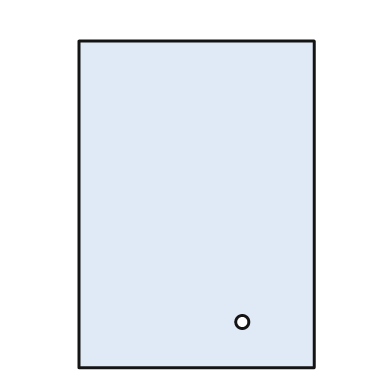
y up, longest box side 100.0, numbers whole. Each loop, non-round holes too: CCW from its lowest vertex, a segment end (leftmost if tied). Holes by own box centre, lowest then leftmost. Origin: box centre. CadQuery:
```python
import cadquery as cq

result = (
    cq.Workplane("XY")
    .moveTo(-36.0, -50.0)
    .lineTo(36.0, -50.0)
    .lineTo(36.0, 50.0)
    .lineTo(-36.0, 50.0)
    .close()
    .moveTo(14.0, -36.0)
    .circle(2.0)
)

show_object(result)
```